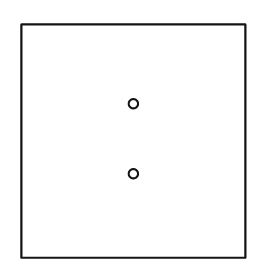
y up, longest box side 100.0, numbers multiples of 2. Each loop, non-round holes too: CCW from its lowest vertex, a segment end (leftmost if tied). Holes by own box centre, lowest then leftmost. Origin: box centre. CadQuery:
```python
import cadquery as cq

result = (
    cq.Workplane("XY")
    .moveTo(-48.0, -50.0)
    .lineTo(48.0, -50.0)
    .lineTo(48.0, 50.0)
    .lineTo(-48.0, 50.0)
    .close()
    .moveTo(0.0, -14.0)
    .circle(2.0)
    .moveTo(0.0, 16.0)
    .circle(2.0)
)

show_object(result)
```